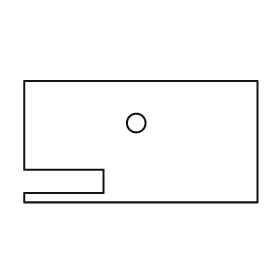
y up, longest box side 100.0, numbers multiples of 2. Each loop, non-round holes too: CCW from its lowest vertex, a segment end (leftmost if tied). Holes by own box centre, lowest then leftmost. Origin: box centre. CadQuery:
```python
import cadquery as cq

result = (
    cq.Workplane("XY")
    .moveTo(-50.0, -26.0)
    .lineTo(50.0, -26.0)
    .lineTo(50.0, 26.0)
    .lineTo(-50.0, 26.0)
    .lineTo(-50.0, -12.0)
    .lineTo(-16.0, -12.0)
    .lineTo(-16.0, -22.0)
    .lineTo(-50.0, -22.0)
    .close()
    .moveTo(-2.0, 8.0)
    .circle(4.0)
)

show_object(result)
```